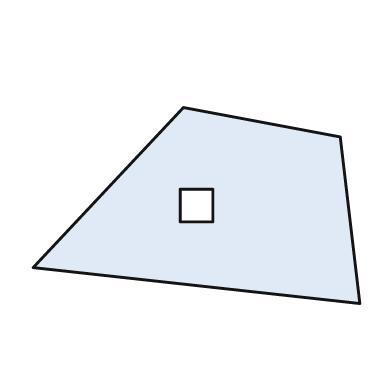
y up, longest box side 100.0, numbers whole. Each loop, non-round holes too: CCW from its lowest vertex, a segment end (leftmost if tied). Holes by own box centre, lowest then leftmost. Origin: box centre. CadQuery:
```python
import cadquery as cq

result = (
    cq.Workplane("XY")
    .moveTo(50.0, -30.0)
    .lineTo(44.0, 21.0)
    .lineTo(-4.0, 30.0)
    .lineTo(-50.0, -19.0)
    .close()
    .moveTo(-5.0, -5.0)
    .lineTo(5.0, -5.0)
    .lineTo(5.0, 5.0)
    .lineTo(-5.0, 5.0)
    .close()
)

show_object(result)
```